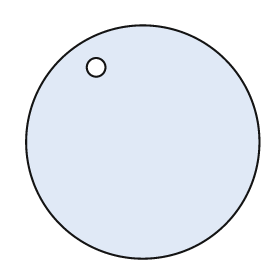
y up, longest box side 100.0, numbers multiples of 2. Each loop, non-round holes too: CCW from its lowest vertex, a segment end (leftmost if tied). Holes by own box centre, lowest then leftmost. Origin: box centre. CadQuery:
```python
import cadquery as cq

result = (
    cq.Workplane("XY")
    .moveTo(0.0, 0.0)
    .circle(50.0)
    .moveTo(-20.0, 32.0)
    .circle(4.0)
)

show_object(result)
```